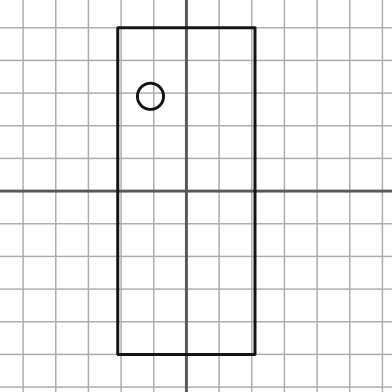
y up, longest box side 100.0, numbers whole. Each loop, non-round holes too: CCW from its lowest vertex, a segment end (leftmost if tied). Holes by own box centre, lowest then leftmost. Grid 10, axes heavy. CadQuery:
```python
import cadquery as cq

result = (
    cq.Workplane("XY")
    .moveTo(-21.0, -50.0)
    .lineTo(21.0, -50.0)
    .lineTo(21.0, 50.0)
    .lineTo(-21.0, 50.0)
    .close()
    .moveTo(-11.0, 29.0)
    .circle(4.0)
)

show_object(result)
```